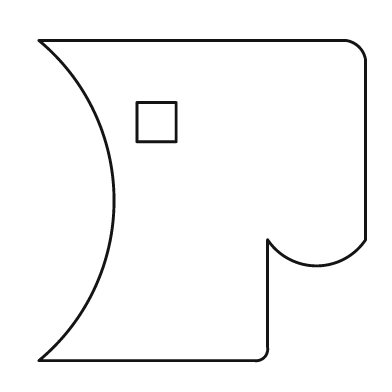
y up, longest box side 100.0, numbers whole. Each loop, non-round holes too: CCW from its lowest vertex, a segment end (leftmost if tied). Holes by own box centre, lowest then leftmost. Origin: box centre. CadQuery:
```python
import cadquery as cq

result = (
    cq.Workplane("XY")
    .moveTo(-50.0, -49.0)
    .lineTo(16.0, -49.0)
    .threePointArc((19.0, -48.0), (20.0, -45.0))
    .lineTo(20.0, -12.0)
    .threePointArc((35.0, -20.0), (50.0, -12.0))
    .lineTo(50.0, 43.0)
    .threePointArc((48.0, 47.0), (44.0, 49.0))
    .lineTo(-50.0, 49.0)
    .threePointArc((-27.0, 0.0), (-50.0, -49.0))
    .close()
    .moveTo(-20.0, 18.0)
    .lineTo(-8.0, 18.0)
    .lineTo(-8.0, 30.0)
    .lineTo(-20.0, 30.0)
    .close()
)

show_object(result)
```